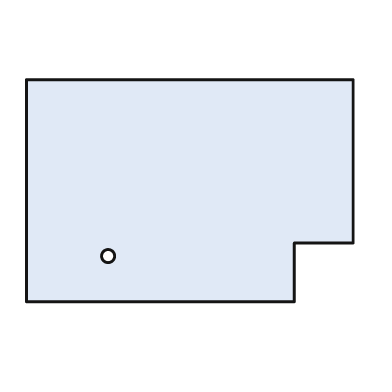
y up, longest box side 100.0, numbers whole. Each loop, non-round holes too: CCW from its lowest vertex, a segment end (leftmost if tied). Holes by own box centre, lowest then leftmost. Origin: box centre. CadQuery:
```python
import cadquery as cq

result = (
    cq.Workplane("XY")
    .moveTo(-50.0, -34.0)
    .lineTo(32.0, -34.0)
    .lineTo(32.0, -16.0)
    .lineTo(50.0, -16.0)
    .lineTo(50.0, 34.0)
    .lineTo(-50.0, 34.0)
    .close()
    .moveTo(-25.0, -20.0)
    .circle(2.0)
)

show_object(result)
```